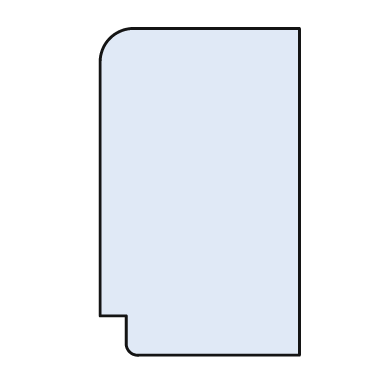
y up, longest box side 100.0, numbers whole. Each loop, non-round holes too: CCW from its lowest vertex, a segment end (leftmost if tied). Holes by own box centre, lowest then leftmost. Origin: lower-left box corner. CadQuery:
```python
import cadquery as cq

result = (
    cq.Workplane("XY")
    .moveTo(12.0, 0.0)
    .lineTo(61.0, 0.0)
    .lineTo(61.0, 100.0)
    .lineTo(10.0, 100.0)
    .threePointArc((3.0, 97.0), (0.0, 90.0))
    .lineTo(0.0, 12.0)
    .lineTo(8.0, 12.0)
    .lineTo(8.0, 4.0)
    .threePointArc((9.0, 1.0), (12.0, 0.0))
    .close()
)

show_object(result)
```